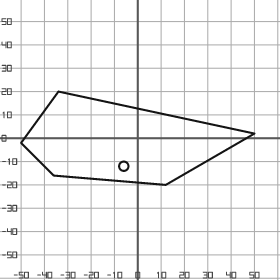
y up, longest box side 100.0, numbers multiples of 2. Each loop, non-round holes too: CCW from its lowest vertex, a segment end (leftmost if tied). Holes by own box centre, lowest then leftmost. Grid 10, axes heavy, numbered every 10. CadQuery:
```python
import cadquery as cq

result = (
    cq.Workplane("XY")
    .moveTo(12.0, -20.0)
    .lineTo(50.0, 2.0)
    .lineTo(-34.0, 20.0)
    .lineTo(-50.0, -2.0)
    .lineTo(-36.0, -16.0)
    .close()
    .moveTo(-6.0, -12.0)
    .circle(2.0)
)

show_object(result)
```